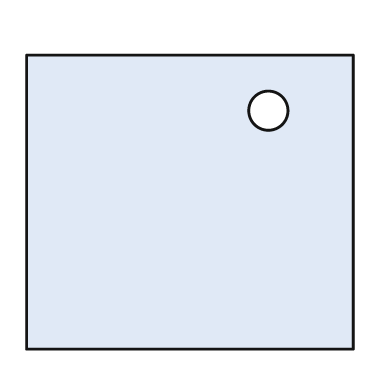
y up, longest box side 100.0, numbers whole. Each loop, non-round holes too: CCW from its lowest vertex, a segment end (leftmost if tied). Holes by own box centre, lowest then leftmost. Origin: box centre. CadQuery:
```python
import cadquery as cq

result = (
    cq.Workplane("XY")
    .moveTo(-50.0, -45.0)
    .lineTo(50.0, -45.0)
    .lineTo(50.0, 45.0)
    .lineTo(-50.0, 45.0)
    .close()
    .moveTo(24.0, 28.0)
    .circle(6.0)
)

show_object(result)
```